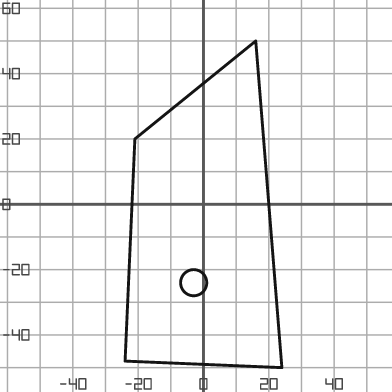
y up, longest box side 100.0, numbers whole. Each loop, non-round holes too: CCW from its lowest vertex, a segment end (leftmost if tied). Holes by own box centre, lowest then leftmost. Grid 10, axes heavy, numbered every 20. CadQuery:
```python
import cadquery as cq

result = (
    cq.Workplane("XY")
    .moveTo(24.0, -50.0)
    .lineTo(16.0, 50.0)
    .lineTo(-21.0, 20.0)
    .lineTo(-24.0, -48.0)
    .close()
    .moveTo(-3.0, -24.0)
    .circle(4.0)
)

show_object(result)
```